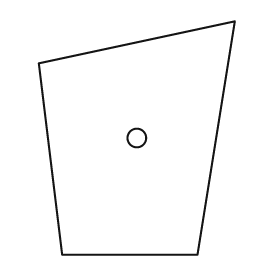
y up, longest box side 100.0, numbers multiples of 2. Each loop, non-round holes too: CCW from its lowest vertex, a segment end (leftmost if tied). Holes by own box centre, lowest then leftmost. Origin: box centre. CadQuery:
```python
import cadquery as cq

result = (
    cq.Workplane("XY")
    .moveTo(-32.0, -50.0)
    .lineTo(26.0, -50.0)
    .lineTo(42.0, 50.0)
    .lineTo(-42.0, 32.0)
    .close()
    .moveTo(0.0, 0.0)
    .circle(4.0)
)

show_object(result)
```